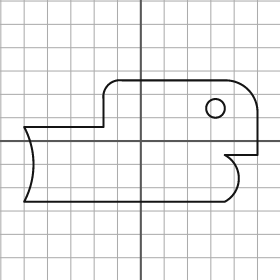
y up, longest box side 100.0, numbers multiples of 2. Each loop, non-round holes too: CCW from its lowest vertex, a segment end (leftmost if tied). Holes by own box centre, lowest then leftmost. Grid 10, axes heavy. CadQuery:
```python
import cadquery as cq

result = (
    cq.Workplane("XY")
    .moveTo(-50.0, -26.0)
    .lineTo(36.0, -26.0)
    .threePointArc((42.0, -16.0), (36.0, -6.0))
    .lineTo(50.0, -6.0)
    .lineTo(50.0, 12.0)
    .threePointArc((46.0, 22.0), (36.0, 26.0))
    .lineTo(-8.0, 26.0)
    .threePointArc((-14.0, 24.0), (-16.0, 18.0))
    .lineTo(-16.0, 6.0)
    .lineTo(-50.0, 6.0)
    .threePointArc((-46.0, -10.0), (-50.0, -26.0))
    .close()
    .moveTo(32.0, 14.0)
    .circle(4.0)
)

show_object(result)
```